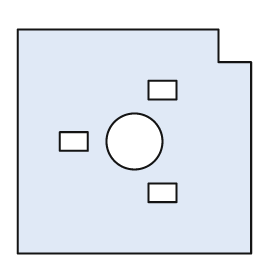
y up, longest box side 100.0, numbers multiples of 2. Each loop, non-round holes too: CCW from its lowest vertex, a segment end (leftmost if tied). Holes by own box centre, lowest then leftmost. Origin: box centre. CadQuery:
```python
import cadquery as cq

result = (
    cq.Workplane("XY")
    .moveTo(-50.0, -48.0)
    .lineTo(50.0, -48.0)
    .lineTo(50.0, 34.0)
    .lineTo(36.0, 34.0)
    .lineTo(36.0, 48.0)
    .lineTo(-50.0, 48.0)
    .close()
    .moveTo(6.0, -26.0)
    .lineTo(18.0, -26.0)
    .lineTo(18.0, -18.0)
    .lineTo(6.0, -18.0)
    .close()
    .moveTo(-32.0, -4.0)
    .lineTo(-20.0, -4.0)
    .lineTo(-20.0, 4.0)
    .lineTo(-32.0, 4.0)
    .close()
    .moveTo(0.0, 0.0)
    .circle(12.0)
    .moveTo(6.0, 18.0)
    .lineTo(18.0, 18.0)
    .lineTo(18.0, 26.0)
    .lineTo(6.0, 26.0)
    .close()
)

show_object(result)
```